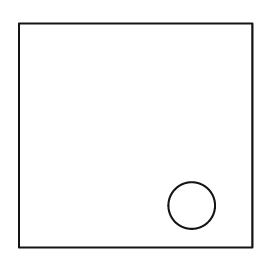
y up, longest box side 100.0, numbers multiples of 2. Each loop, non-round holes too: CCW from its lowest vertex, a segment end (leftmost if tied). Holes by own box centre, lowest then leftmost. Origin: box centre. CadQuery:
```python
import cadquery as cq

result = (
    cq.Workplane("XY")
    .moveTo(-50.0, -48.0)
    .lineTo(50.0, -48.0)
    .lineTo(50.0, 48.0)
    .lineTo(-50.0, 48.0)
    .close()
    .moveTo(24.0, -30.0)
    .circle(10.0)
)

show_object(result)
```